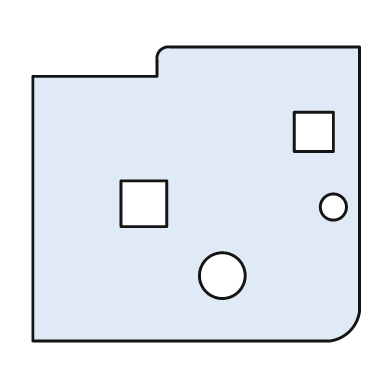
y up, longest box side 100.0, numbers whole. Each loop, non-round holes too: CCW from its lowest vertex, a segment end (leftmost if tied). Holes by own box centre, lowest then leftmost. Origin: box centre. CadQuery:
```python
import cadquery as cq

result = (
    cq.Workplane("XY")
    .moveTo(-50.0, -45.0)
    .lineTo(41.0, -45.0)
    .threePointArc((47.0, -42.0), (50.0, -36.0))
    .lineTo(50.0, 45.0)
    .lineTo(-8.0, 45.0)
    .threePointArc((-11.0, 44.0), (-12.0, 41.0))
    .lineTo(-12.0, 36.0)
    .lineTo(-50.0, 36.0)
    .close()
    .moveTo(8.0, -25.0)
    .circle(7.0)
    .moveTo(42.0, -4.0)
    .circle(4.0)
    .moveTo(-23.0, -10.0)
    .lineTo(-9.0, -10.0)
    .lineTo(-9.0, 4.0)
    .lineTo(-23.0, 4.0)
    .close()
    .moveTo(30.0, 13.0)
    .lineTo(42.0, 13.0)
    .lineTo(42.0, 25.0)
    .lineTo(30.0, 25.0)
    .close()
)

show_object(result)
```